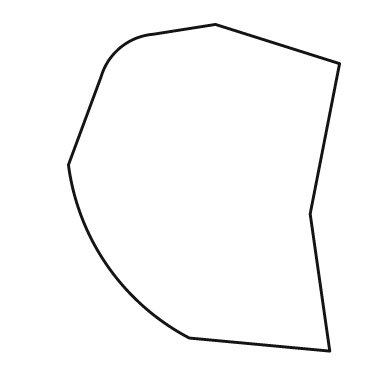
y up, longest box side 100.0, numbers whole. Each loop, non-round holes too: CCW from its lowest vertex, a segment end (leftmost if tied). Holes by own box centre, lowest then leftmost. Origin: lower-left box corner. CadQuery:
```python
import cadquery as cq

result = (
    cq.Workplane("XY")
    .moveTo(80.0, 0.0)
    .lineTo(74.0, 42.0)
    .lineTo(83.0, 88.0)
    .lineTo(45.0, 100.0)
    .lineTo(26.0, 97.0)
    .threePointArc((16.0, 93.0), (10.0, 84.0))
    .lineTo(0.0, 57.0)
    .threePointArc((12.0, 26.0), (37.0, 4.0))
    .close()
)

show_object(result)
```